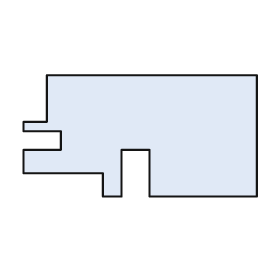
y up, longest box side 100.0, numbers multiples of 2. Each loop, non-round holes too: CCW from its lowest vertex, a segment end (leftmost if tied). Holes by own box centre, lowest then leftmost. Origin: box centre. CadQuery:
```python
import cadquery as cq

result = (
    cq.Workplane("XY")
    .moveTo(-16.0, -26.0)
    .lineTo(-8.0, -26.0)
    .lineTo(-8.0, -6.0)
    .lineTo(4.0, -6.0)
    .lineTo(4.0, -26.0)
    .lineTo(50.0, -26.0)
    .lineTo(50.0, 26.0)
    .lineTo(-40.0, 26.0)
    .lineTo(-40.0, 6.0)
    .lineTo(-50.0, 6.0)
    .lineTo(-50.0, 2.0)
    .lineTo(-34.0, 2.0)
    .lineTo(-34.0, -6.0)
    .lineTo(-50.0, -6.0)
    .lineTo(-50.0, -16.0)
    .lineTo(-16.0, -16.0)
    .close()
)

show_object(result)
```